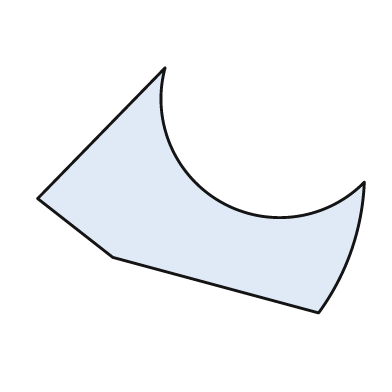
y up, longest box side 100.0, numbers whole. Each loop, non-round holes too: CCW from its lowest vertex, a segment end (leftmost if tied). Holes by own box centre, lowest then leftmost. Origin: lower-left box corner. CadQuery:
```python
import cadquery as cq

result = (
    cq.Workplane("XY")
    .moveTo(86.0, 0.0)
    .threePointArc((96.0, 19.0), (100.0, 40.0))
    .threePointArc((56.0, 34.0), (39.0, 75.0))
    .lineTo(0.0, 35.0)
    .lineTo(23.0, 17.0)
    .close()
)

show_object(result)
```